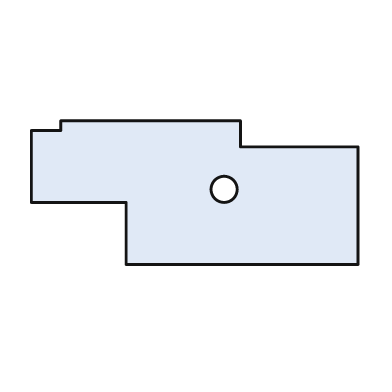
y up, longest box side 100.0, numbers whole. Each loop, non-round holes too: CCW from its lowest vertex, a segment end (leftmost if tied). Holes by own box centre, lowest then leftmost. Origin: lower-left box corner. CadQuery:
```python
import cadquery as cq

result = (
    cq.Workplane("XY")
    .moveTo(29.0, 0.0)
    .lineTo(100.0, 0.0)
    .lineTo(100.0, 36.0)
    .lineTo(64.0, 36.0)
    .lineTo(64.0, 44.0)
    .lineTo(9.0, 44.0)
    .lineTo(9.0, 41.0)
    .lineTo(0.0, 41.0)
    .lineTo(0.0, 19.0)
    .lineTo(29.0, 19.0)
    .close()
    .moveTo(59.0, 23.0)
    .circle(4.0)
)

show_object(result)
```